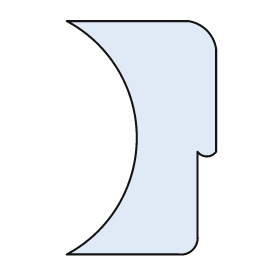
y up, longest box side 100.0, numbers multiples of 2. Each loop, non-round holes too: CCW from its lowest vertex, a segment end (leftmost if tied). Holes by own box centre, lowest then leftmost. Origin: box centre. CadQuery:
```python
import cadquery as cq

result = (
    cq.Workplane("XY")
    .moveTo(-32.0, -50.0)
    .lineTo(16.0, -50.0)
    .threePointArc((22.0, -48.0), (24.0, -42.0))
    .lineTo(24.0, -6.0)
    .threePointArc((28.0, -8.0), (32.0, -6.0))
    .lineTo(32.0, 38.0)
    .threePointArc((28.0, 46.0), (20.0, 50.0))
    .lineTo(-32.0, 50.0)
    .threePointArc((-2.0, 0.0), (-32.0, -50.0))
    .close()
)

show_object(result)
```